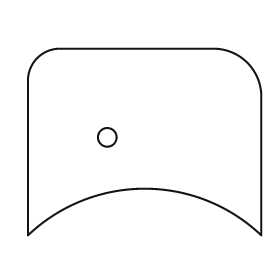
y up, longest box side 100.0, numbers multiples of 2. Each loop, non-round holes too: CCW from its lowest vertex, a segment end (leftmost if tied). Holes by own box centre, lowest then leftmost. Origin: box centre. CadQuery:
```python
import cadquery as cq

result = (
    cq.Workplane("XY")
    .moveTo(-50.0, -40.0)
    .threePointArc((0.0, -20.0), (50.0, -40.0))
    .lineTo(50.0, 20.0)
    .threePointArc((44.0, 34.0), (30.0, 40.0))
    .lineTo(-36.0, 40.0)
    .threePointArc((-46.0, 36.0), (-50.0, 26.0))
    .close()
    .moveTo(-16.0, 2.0)
    .circle(4.0)
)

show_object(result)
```